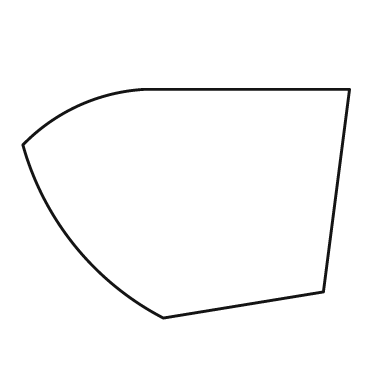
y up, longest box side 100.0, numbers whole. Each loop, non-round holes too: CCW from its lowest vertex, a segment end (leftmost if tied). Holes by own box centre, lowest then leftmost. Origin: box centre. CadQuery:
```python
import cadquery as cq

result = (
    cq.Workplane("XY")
    .moveTo(-7.0, -35.0)
    .lineTo(42.0, -27.0)
    .lineTo(50.0, 35.0)
    .lineTo(-13.0, 35.0)
    .threePointArc((-33.0, 30.0), (-50.0, 18.0))
    .threePointArc((-34.0, -13.0), (-7.0, -35.0))
    .close()
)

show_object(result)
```